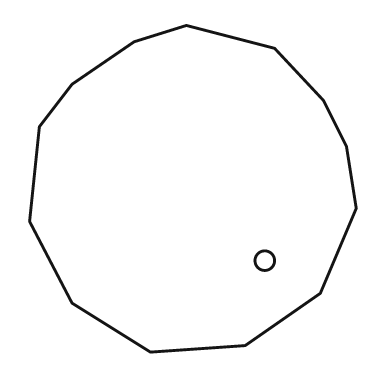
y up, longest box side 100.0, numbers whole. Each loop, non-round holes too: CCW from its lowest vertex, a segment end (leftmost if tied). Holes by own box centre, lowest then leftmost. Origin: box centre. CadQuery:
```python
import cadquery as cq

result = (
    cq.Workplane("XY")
    .moveTo(-13.0, -50.0)
    .lineTo(16.0, -48.0)
    .lineTo(39.0, -32.0)
    .lineTo(50.0, -6.0)
    .lineTo(47.0, 13.0)
    .lineTo(40.0, 27.0)
    .lineTo(25.0, 43.0)
    .lineTo(-2.0, 50.0)
    .lineTo(-18.0, 45.0)
    .lineTo(-37.0, 32.0)
    .lineTo(-47.0, 19.0)
    .lineTo(-50.0, -10.0)
    .lineTo(-37.0, -35.0)
    .close()
    .moveTo(22.0, -22.0)
    .circle(3.0)
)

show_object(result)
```